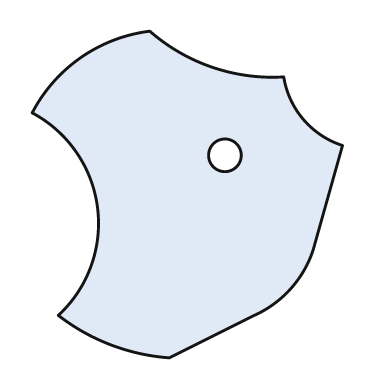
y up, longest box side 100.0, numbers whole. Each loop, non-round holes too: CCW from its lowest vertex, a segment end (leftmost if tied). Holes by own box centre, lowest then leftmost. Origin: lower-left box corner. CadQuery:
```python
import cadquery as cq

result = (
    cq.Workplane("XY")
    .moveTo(42.0, 0.0)
    .lineTo(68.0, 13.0)
    .threePointArc((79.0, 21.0), (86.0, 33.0))
    .lineTo(95.0, 65.0)
    .threePointArc((83.0, 73.0), (77.0, 86.0))
    .threePointArc((55.0, 89.0), (36.0, 100.0))
    .threePointArc((15.0, 92.0), (0.0, 75.0))
    .threePointArc((20.0, 46.0), (8.0, 13.0))
    .threePointArc((24.0, 4.0), (42.0, 0.0))
    .close()
    .moveTo(59.0, 62.0)
    .circle(5.0)
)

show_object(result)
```